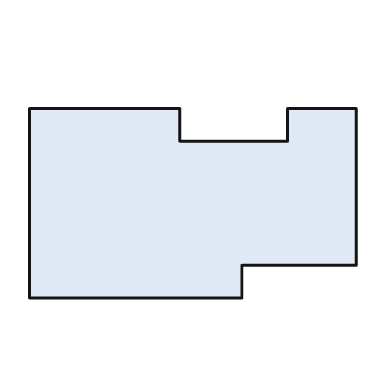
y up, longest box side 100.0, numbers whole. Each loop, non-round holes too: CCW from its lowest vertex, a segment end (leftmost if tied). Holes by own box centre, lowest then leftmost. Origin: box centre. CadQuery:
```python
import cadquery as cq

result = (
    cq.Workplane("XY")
    .moveTo(-50.0, -29.0)
    .lineTo(15.0, -29.0)
    .lineTo(15.0, -19.0)
    .lineTo(50.0, -19.0)
    .lineTo(50.0, 29.0)
    .lineTo(29.0, 29.0)
    .lineTo(29.0, 19.0)
    .lineTo(-4.0, 19.0)
    .lineTo(-4.0, 29.0)
    .lineTo(-50.0, 29.0)
    .close()
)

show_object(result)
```